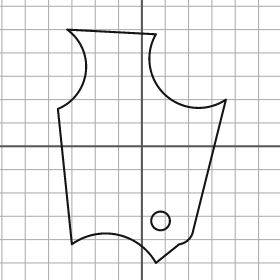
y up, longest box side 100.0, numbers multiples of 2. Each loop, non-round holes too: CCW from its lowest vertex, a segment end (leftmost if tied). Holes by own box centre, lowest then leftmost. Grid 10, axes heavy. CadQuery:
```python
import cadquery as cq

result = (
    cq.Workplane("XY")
    .moveTo(6.0, -50.0)
    .lineTo(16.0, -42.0)
    .threePointArc((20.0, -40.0), (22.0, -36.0))
    .lineTo(36.0, 20.0)
    .threePointArc((10.0, 22.0), (6.0, 48.0))
    .lineTo(-32.0, 50.0)
    .threePointArc((-24.0, 32.0), (-36.0, 16.0))
    .lineTo(-30.0, -42.0)
    .threePointArc((-10.0, -38.0), (6.0, -50.0))
    .close()
    .moveTo(8.0, -32.0)
    .circle(4.0)
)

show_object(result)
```